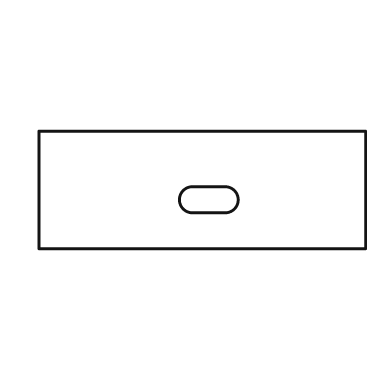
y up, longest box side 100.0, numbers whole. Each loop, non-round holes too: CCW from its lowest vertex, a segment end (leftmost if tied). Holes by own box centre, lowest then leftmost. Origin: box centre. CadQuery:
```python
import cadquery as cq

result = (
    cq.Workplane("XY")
    .moveTo(-50.0, -18.0)
    .lineTo(50.0, -18.0)
    .lineTo(50.0, 18.0)
    .lineTo(-50.0, 18.0)
    .close()
    .moveTo(-3.0, -7.0)
    .lineTo(7.0, -7.0)
    .threePointArc((11.0, -3.0), (7.0, 1.0))
    .lineTo(-3.0, 1.0)
    .threePointArc((-7.0, -3.0), (-3.0, -7.0))
    .close()
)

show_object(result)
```